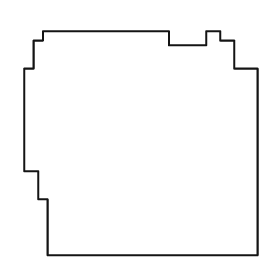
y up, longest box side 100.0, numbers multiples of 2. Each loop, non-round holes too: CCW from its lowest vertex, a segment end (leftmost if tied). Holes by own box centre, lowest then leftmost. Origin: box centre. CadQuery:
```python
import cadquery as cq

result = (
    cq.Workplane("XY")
    .moveTo(-40.0, -48.0)
    .lineTo(50.0, -48.0)
    .lineTo(50.0, 32.0)
    .lineTo(40.0, 32.0)
    .lineTo(40.0, 44.0)
    .lineTo(34.0, 44.0)
    .lineTo(34.0, 48.0)
    .lineTo(28.0, 48.0)
    .lineTo(28.0, 42.0)
    .lineTo(12.0, 42.0)
    .lineTo(12.0, 48.0)
    .lineTo(-42.0, 48.0)
    .lineTo(-42.0, 44.0)
    .lineTo(-46.0, 44.0)
    .lineTo(-46.0, 32.0)
    .lineTo(-50.0, 32.0)
    .lineTo(-50.0, -12.0)
    .lineTo(-44.0, -12.0)
    .lineTo(-44.0, -24.0)
    .lineTo(-40.0, -24.0)
    .close()
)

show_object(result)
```